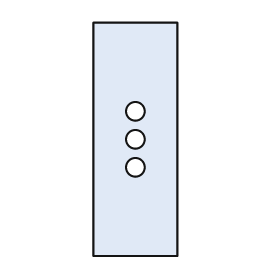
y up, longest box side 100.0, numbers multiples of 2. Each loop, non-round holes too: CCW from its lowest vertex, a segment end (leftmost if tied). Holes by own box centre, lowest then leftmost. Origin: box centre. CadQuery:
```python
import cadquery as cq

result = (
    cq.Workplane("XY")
    .moveTo(-18.0, -50.0)
    .lineTo(18.0, -50.0)
    .lineTo(18.0, 50.0)
    .lineTo(-18.0, 50.0)
    .close()
    .moveTo(0.0, -12.0)
    .circle(4.0)
    .moveTo(0.0, 0.0)
    .circle(4.0)
    .moveTo(0.0, 12.0)
    .circle(4.0)
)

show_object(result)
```